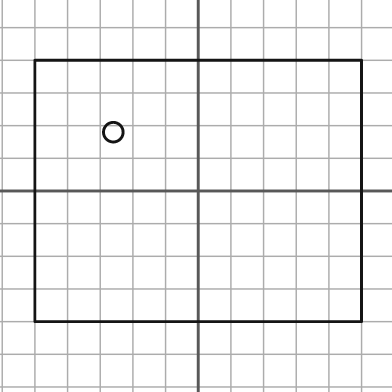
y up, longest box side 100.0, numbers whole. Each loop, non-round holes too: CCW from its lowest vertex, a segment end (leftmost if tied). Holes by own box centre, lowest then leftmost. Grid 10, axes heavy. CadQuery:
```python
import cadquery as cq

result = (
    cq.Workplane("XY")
    .moveTo(-50.0, -40.0)
    .lineTo(50.0, -40.0)
    .lineTo(50.0, 40.0)
    .lineTo(-50.0, 40.0)
    .close()
    .moveTo(-26.0, 18.0)
    .circle(3.0)
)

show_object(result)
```